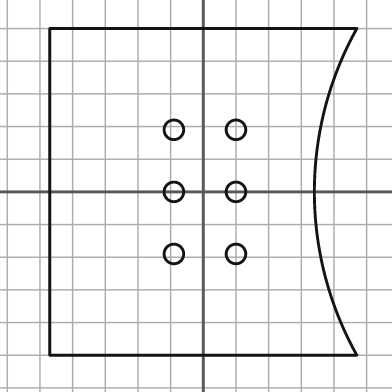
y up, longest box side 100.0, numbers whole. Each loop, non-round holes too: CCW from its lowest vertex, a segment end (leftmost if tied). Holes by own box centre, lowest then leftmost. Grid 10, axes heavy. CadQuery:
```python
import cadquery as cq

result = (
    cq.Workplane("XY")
    .moveTo(-47.0, -50.0)
    .lineTo(47.0, -50.0)
    .threePointArc((34.0, 0.0), (47.0, 50.0))
    .lineTo(-47.0, 50.0)
    .close()
    .moveTo(-9.0, -19.0)
    .circle(3.0)
    .moveTo(10.0, -19.0)
    .circle(3.0)
    .moveTo(-9.0, 0.0)
    .circle(3.0)
    .moveTo(10.0, 0.0)
    .circle(3.0)
    .moveTo(-9.0, 19.0)
    .circle(3.0)
    .moveTo(10.0, 19.0)
    .circle(3.0)
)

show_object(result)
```